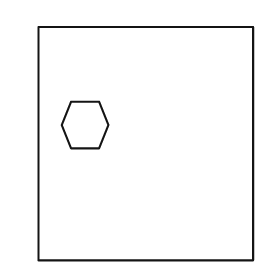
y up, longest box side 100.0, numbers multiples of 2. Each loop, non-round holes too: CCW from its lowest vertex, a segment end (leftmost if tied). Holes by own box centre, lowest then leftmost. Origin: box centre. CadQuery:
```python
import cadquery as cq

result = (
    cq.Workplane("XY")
    .moveTo(-46.0, -50.0)
    .lineTo(46.0, -50.0)
    .lineTo(46.0, 50.0)
    .lineTo(-46.0, 50.0)
    .close()
    .moveTo(-32.0, -2.0)
    .lineTo(-20.0, -2.0)
    .lineTo(-16.0, 8.0)
    .lineTo(-20.0, 18.0)
    .lineTo(-32.0, 18.0)
    .lineTo(-36.0, 8.0)
    .close()
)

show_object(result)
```